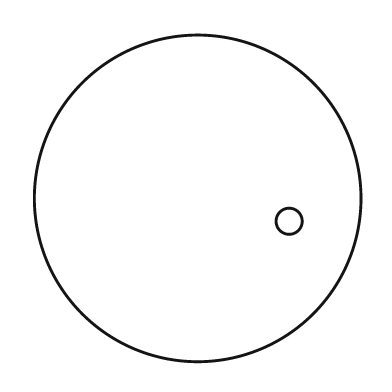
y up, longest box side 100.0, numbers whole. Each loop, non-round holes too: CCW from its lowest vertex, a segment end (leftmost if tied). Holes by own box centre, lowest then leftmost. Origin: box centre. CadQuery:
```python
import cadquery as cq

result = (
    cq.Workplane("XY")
    .moveTo(0.0, 0.0)
    .circle(50.0)
    .moveTo(28.0, -7.0)
    .circle(4.0)
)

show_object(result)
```